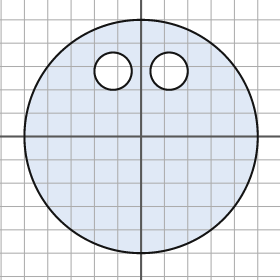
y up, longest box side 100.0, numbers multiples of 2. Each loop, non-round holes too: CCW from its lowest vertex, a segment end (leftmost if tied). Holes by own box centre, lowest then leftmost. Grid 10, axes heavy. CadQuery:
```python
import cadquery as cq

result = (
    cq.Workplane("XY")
    .moveTo(0.0, 0.0)
    .circle(50.0)
    .moveTo(-12.0, 28.0)
    .circle(8.0)
    .moveTo(12.0, 28.0)
    .circle(8.0)
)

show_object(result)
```